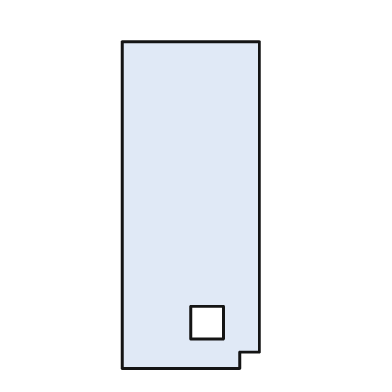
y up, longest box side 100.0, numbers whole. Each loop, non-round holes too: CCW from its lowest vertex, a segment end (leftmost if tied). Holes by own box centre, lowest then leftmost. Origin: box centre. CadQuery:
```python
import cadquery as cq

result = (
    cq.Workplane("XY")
    .moveTo(-21.0, -50.0)
    .lineTo(15.0, -50.0)
    .lineTo(15.0, -45.0)
    .lineTo(21.0, -45.0)
    .lineTo(21.0, 50.0)
    .lineTo(-21.0, 50.0)
    .close()
    .moveTo(0.0, -41.0)
    .lineTo(10.0, -41.0)
    .lineTo(10.0, -31.0)
    .lineTo(0.0, -31.0)
    .close()
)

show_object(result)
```